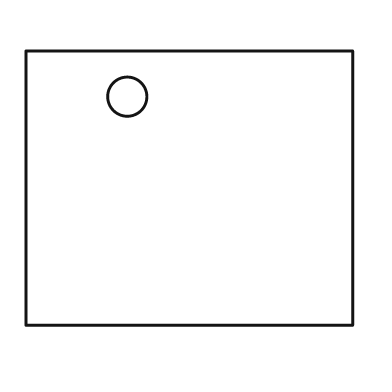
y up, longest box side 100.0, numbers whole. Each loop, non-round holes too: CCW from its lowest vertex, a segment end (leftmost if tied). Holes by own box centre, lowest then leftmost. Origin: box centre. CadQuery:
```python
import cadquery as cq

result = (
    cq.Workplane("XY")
    .moveTo(-50.0, -42.0)
    .lineTo(50.0, -42.0)
    .lineTo(50.0, 42.0)
    .lineTo(-50.0, 42.0)
    .close()
    .moveTo(-19.0, 28.0)
    .circle(6.0)
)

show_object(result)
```